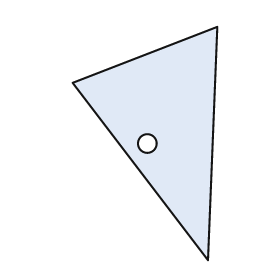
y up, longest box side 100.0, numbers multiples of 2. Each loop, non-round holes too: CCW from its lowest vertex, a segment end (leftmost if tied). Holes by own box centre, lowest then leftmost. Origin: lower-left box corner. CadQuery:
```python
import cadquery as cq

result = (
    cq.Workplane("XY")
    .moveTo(58.0, 0.0)
    .lineTo(62.0, 100.0)
    .lineTo(0.0, 76.0)
    .close()
    .moveTo(32.0, 50.0)
    .circle(4.0)
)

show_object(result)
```